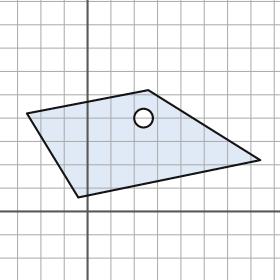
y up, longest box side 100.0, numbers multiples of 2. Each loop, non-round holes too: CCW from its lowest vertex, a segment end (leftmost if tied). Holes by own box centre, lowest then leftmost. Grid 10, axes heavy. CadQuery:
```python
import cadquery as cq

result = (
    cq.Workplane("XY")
    .moveTo(-4.0, 6.0)
    .lineTo(74.0, 22.0)
    .lineTo(26.0, 52.0)
    .lineTo(-26.0, 42.0)
    .close()
    .moveTo(24.0, 40.0)
    .circle(4.0)
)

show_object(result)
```